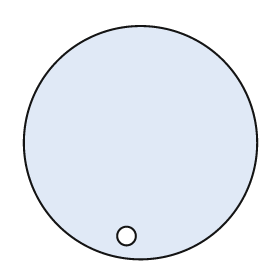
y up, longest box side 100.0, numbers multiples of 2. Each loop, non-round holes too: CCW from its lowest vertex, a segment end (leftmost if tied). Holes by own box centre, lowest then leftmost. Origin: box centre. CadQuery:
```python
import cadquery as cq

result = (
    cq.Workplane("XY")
    .moveTo(0.0, 0.0)
    .circle(50.0)
    .moveTo(-6.0, -40.0)
    .circle(4.0)
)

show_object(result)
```